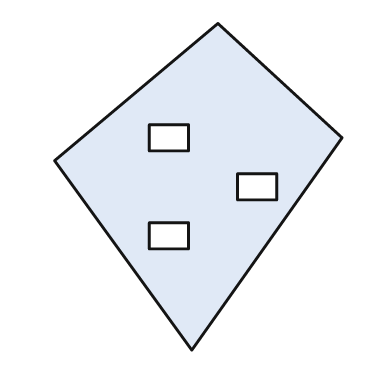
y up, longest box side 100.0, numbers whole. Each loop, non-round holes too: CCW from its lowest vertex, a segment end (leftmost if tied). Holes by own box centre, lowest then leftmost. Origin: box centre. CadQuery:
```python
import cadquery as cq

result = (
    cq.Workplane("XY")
    .moveTo(-2.0, -50.0)
    .lineTo(44.0, 15.0)
    .lineTo(6.0, 50.0)
    .lineTo(-44.0, 8.0)
    .close()
    .moveTo(-15.0, -19.0)
    .lineTo(-3.0, -19.0)
    .lineTo(-3.0, -11.0)
    .lineTo(-15.0, -11.0)
    .close()
    .moveTo(12.0, -4.0)
    .lineTo(24.0, -4.0)
    .lineTo(24.0, 4.0)
    .lineTo(12.0, 4.0)
    .close()
    .moveTo(-15.0, 11.0)
    .lineTo(-3.0, 11.0)
    .lineTo(-3.0, 19.0)
    .lineTo(-15.0, 19.0)
    .close()
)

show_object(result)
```